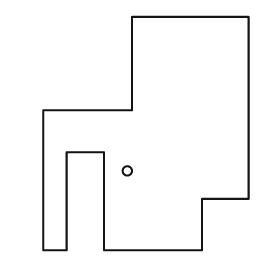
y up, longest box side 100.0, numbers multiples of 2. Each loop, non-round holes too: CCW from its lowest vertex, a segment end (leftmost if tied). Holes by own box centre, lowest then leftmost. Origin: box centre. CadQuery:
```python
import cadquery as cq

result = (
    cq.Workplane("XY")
    .moveTo(-44.0, -50.0)
    .lineTo(-34.0, -50.0)
    .lineTo(-34.0, -8.0)
    .lineTo(-18.0, -8.0)
    .lineTo(-18.0, -50.0)
    .lineTo(24.0, -50.0)
    .lineTo(24.0, -28.0)
    .lineTo(44.0, -28.0)
    .lineTo(44.0, 50.0)
    .lineTo(-6.0, 50.0)
    .lineTo(-6.0, 10.0)
    .lineTo(-44.0, 10.0)
    .close()
    .moveTo(-8.0, -16.0)
    .circle(2.0)
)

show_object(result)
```